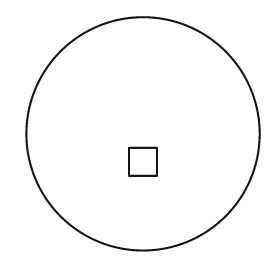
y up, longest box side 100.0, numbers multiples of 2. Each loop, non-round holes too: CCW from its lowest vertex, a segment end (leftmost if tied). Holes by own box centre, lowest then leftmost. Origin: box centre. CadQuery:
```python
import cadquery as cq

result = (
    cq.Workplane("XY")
    .moveTo(0.0, 0.0)
    .circle(50.0)
    .moveTo(-6.0, -18.0)
    .lineTo(6.0, -18.0)
    .lineTo(6.0, -6.0)
    .lineTo(-6.0, -6.0)
    .close()
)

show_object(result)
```